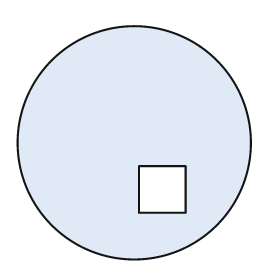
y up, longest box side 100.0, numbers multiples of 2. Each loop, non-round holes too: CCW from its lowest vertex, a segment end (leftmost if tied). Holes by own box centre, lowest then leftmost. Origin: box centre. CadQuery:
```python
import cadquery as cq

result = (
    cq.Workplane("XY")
    .moveTo(0.0, 0.0)
    .circle(50.0)
    .moveTo(2.0, -30.0)
    .lineTo(22.0, -30.0)
    .lineTo(22.0, -10.0)
    .lineTo(2.0, -10.0)
    .close()
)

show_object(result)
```